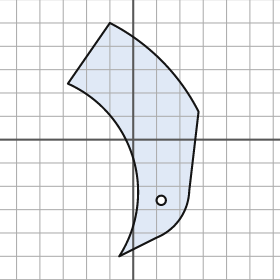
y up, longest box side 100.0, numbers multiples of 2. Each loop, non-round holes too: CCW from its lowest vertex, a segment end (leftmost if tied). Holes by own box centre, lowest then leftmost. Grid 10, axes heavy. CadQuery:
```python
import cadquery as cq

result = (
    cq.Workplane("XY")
    .moveTo(-6.0, -50.0)
    .lineTo(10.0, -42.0)
    .threePointArc((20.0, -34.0), (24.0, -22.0))
    .lineTo(28.0, 12.0)
    .threePointArc((12.0, 34.0), (-10.0, 50.0))
    .lineTo(-28.0, 24.0)
    .threePointArc((0.0, -8.0), (-6.0, -50.0))
    .close()
    .moveTo(12.0, -26.0)
    .circle(2.0)
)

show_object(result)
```